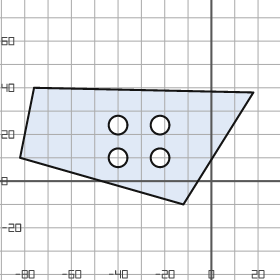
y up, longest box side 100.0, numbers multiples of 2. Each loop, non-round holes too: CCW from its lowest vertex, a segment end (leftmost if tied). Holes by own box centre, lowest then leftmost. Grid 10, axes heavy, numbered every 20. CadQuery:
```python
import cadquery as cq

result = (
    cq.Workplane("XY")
    .moveTo(-12.0, -10.0)
    .lineTo(18.0, 38.0)
    .lineTo(-76.0, 40.0)
    .lineTo(-82.0, 10.0)
    .close()
    .moveTo(-40.0, 10.0)
    .circle(4.0)
    .moveTo(-22.0, 10.0)
    .circle(4.0)
    .moveTo(-40.0, 24.0)
    .circle(4.0)
    .moveTo(-22.0, 24.0)
    .circle(4.0)
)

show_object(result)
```